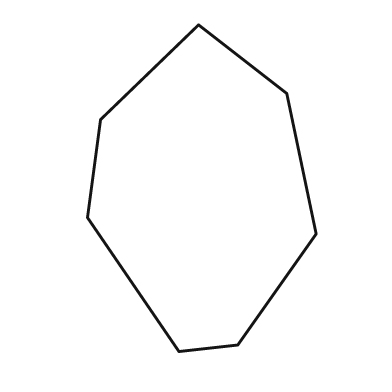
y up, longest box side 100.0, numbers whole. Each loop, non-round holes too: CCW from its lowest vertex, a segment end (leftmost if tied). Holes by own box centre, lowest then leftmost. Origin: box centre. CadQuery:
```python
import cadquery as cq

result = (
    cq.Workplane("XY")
    .moveTo(-7.0, -50.0)
    .lineTo(11.0, -48.0)
    .lineTo(35.0, -14.0)
    .lineTo(26.0, 29.0)
    .lineTo(-1.0, 50.0)
    .lineTo(-31.0, 21.0)
    .lineTo(-35.0, -9.0)
    .close()
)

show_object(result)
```